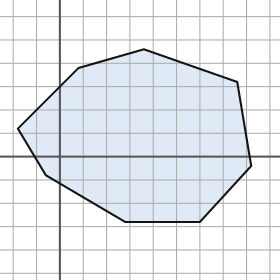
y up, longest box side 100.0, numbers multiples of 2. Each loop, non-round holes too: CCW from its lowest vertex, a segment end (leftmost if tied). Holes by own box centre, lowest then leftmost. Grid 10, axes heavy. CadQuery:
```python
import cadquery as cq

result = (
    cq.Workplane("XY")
    .moveTo(28.0, -28.0)
    .lineTo(60.0, -28.0)
    .lineTo(82.0, -4.0)
    .lineTo(76.0, 32.0)
    .lineTo(36.0, 46.0)
    .lineTo(8.0, 38.0)
    .lineTo(-18.0, 12.0)
    .lineTo(-6.0, -8.0)
    .close()
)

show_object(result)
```